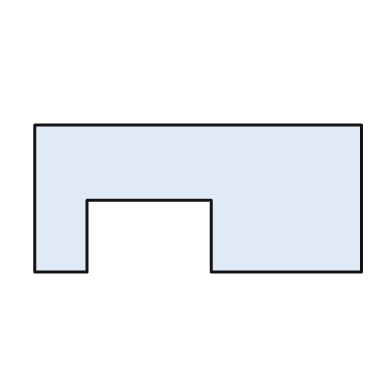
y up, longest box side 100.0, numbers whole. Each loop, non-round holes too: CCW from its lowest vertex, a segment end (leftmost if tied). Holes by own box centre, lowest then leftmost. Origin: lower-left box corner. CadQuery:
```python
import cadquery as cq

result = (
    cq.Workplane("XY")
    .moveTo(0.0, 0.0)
    .lineTo(16.0, 0.0)
    .lineTo(16.0, 22.0)
    .lineTo(54.0, 22.0)
    .lineTo(54.0, 0.0)
    .lineTo(100.0, 0.0)
    .lineTo(100.0, 45.0)
    .lineTo(0.0, 45.0)
    .close()
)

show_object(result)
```